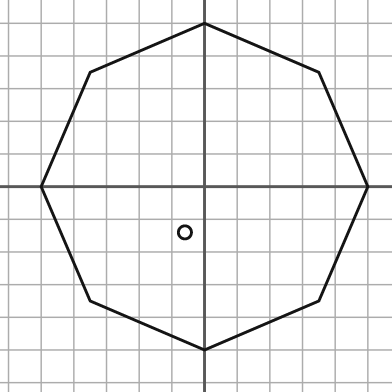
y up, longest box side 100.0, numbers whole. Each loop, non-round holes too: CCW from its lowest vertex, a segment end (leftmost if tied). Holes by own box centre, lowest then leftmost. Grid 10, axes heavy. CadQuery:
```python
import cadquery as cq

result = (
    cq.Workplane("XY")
    .moveTo(0.0, -50.0)
    .lineTo(35.0, -35.0)
    .lineTo(50.0, 0.0)
    .lineTo(35.0, 35.0)
    .lineTo(0.0, 50.0)
    .lineTo(-35.0, 35.0)
    .lineTo(-50.0, 0.0)
    .lineTo(-35.0, -35.0)
    .close()
    .moveTo(-6.0, -14.0)
    .circle(2.0)
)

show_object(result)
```